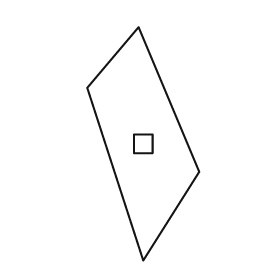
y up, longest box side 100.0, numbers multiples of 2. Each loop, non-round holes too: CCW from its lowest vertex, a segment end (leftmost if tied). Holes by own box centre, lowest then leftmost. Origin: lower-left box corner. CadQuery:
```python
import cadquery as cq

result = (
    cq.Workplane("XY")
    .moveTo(24.0, 0.0)
    .lineTo(48.0, 38.0)
    .lineTo(22.0, 100.0)
    .lineTo(0.0, 74.0)
    .close()
    .moveTo(20.0, 46.0)
    .lineTo(28.0, 46.0)
    .lineTo(28.0, 54.0)
    .lineTo(20.0, 54.0)
    .close()
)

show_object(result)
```